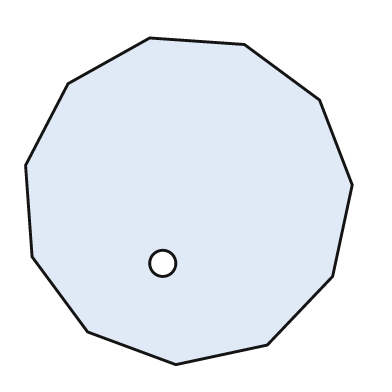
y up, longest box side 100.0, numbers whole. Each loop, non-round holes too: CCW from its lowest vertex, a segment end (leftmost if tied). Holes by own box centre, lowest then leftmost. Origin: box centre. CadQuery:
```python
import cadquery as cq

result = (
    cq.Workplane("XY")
    .moveTo(-4.0, -50.0)
    .lineTo(24.0, -44.0)
    .lineTo(44.0, -23.0)
    .lineTo(50.0, 5.0)
    .lineTo(40.0, 31.0)
    .lineTo(17.0, 48.0)
    .lineTo(-12.0, 50.0)
    .lineTo(-37.0, 36.0)
    .lineTo(-50.0, 11.0)
    .lineTo(-48.0, -17.0)
    .lineTo(-31.0, -40.0)
    .close()
    .moveTo(-8.0, -19.0)
    .circle(4.0)
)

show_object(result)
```